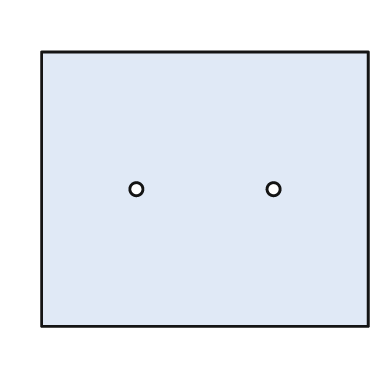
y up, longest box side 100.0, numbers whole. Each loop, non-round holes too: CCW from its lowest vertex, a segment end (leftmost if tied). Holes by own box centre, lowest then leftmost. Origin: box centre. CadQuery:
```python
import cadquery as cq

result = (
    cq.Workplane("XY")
    .moveTo(-50.0, -42.0)
    .lineTo(50.0, -42.0)
    .lineTo(50.0, 42.0)
    .lineTo(-50.0, 42.0)
    .close()
    .moveTo(-21.0, 0.0)
    .circle(2.0)
    .moveTo(21.0, 0.0)
    .circle(2.0)
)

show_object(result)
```